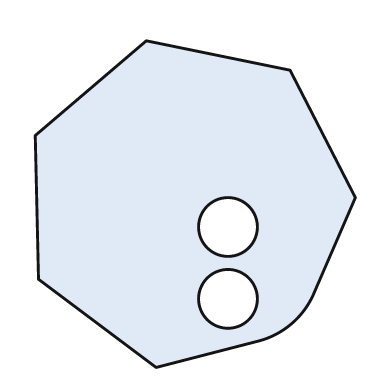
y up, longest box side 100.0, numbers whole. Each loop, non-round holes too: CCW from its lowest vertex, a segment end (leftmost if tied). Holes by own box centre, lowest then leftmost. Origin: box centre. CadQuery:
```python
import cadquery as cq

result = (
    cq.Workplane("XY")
    .moveTo(-12.0, -50.0)
    .lineTo(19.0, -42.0)
    .threePointArc((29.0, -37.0), (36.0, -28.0))
    .lineTo(49.0, 2.0)
    .lineTo(29.0, 41.0)
    .lineTo(-15.0, 50.0)
    .lineTo(-49.0, 21.0)
    .lineTo(-48.0, -23.0)
    .close()
    .moveTo(10.0, -29.0)
    .circle(9.0)
    .moveTo(10.0, -7.0)
    .circle(9.0)
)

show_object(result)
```